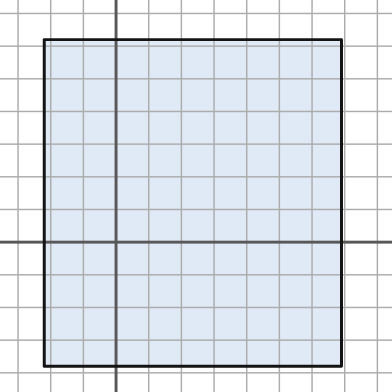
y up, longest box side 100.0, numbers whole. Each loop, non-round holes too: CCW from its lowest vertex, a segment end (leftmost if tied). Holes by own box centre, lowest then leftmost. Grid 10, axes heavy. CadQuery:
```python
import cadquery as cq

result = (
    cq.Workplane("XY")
    .moveTo(-22.0, -38.0)
    .lineTo(69.0, -38.0)
    .lineTo(69.0, 62.0)
    .lineTo(-22.0, 62.0)
    .close()
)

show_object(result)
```